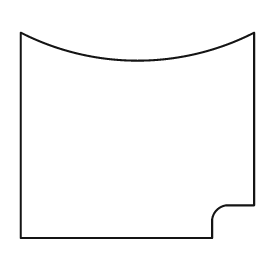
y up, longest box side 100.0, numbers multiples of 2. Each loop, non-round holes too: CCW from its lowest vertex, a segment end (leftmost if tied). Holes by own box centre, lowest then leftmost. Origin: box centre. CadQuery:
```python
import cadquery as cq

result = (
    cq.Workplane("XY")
    .moveTo(-50.0, -44.0)
    .lineTo(32.0, -44.0)
    .lineTo(32.0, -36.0)
    .threePointArc((34.0, -32.0), (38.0, -30.0))
    .lineTo(50.0, -30.0)
    .lineTo(50.0, 44.0)
    .threePointArc((0.0, 32.0), (-50.0, 44.0))
    .close()
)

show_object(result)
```